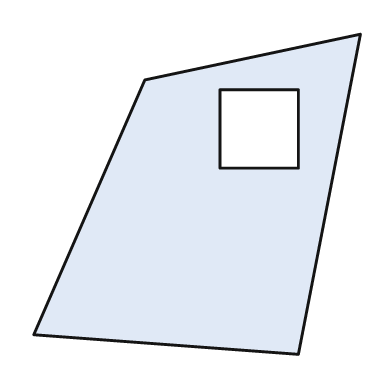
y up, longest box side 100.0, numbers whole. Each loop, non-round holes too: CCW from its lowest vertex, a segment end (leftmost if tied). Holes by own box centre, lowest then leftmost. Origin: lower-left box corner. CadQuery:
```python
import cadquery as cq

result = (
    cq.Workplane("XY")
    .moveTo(81.0, 0.0)
    .lineTo(100.0, 98.0)
    .lineTo(34.0, 84.0)
    .lineTo(0.0, 6.0)
    .close()
    .moveTo(57.0, 57.0)
    .lineTo(81.0, 57.0)
    .lineTo(81.0, 81.0)
    .lineTo(57.0, 81.0)
    .close()
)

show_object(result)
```